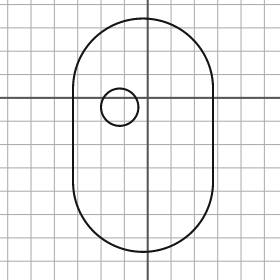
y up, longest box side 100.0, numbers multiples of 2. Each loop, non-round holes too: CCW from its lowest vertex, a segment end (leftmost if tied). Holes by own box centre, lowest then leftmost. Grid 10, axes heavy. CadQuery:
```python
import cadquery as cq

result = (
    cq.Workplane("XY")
    .moveTo(-32.0, -36.0)
    .threePointArc((-2.0, -66.0), (28.0, -36.0))
    .lineTo(28.0, 4.0)
    .threePointArc((-2.0, 34.0), (-32.0, 4.0))
    .close()
    .moveTo(-12.0, -4.0)
    .circle(8.0)
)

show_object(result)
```